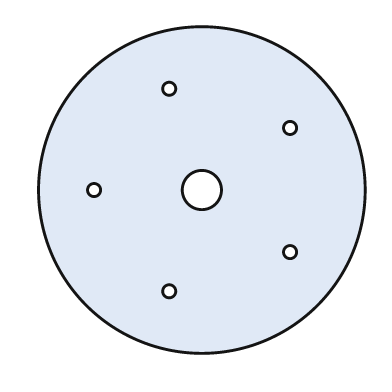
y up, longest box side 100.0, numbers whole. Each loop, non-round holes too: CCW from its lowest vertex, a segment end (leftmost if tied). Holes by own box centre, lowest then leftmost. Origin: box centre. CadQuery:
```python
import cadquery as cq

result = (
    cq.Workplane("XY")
    .moveTo(0.0, 0.0)
    .circle(50.0)
    .moveTo(-10.0, -31.0)
    .circle(2.0)
    .moveTo(27.0, -19.0)
    .circle(2.0)
    .moveTo(-33.0, 0.0)
    .circle(2.0)
    .moveTo(0.0, 0.0)
    .circle(6.0)
    .moveTo(27.0, 19.0)
    .circle(2.0)
    .moveTo(-10.0, 31.0)
    .circle(2.0)
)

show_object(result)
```